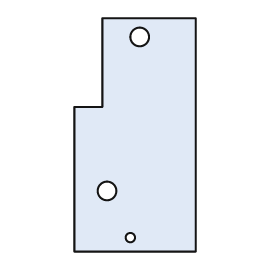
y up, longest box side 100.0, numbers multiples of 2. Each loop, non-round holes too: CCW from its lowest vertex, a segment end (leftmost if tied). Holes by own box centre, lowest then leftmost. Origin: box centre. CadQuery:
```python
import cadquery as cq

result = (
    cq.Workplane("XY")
    .moveTo(-26.0, -50.0)
    .lineTo(26.0, -50.0)
    .lineTo(26.0, 50.0)
    .lineTo(-14.0, 50.0)
    .lineTo(-14.0, 12.0)
    .lineTo(-26.0, 12.0)
    .close()
    .moveTo(-2.0, -44.0)
    .circle(2.0)
    .moveTo(-12.0, -24.0)
    .circle(4.0)
    .moveTo(2.0, 42.0)
    .circle(4.0)
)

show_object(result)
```